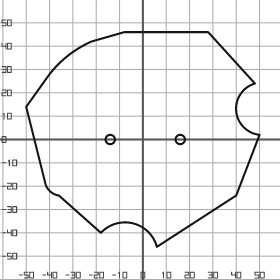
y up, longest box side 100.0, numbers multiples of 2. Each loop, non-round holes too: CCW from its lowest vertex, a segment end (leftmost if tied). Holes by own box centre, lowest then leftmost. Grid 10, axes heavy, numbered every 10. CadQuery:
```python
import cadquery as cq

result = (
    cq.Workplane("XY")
    .moveTo(6.0, -46.0)
    .lineTo(40.0, -24.0)
    .lineTo(50.0, 2.0)
    .threePointArc((40.0, 12.0), (48.0, 24.0))
    .lineTo(28.0, 46.0)
    .lineTo(-8.0, 46.0)
    .lineTo(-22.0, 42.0)
    .threePointArc((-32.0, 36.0), (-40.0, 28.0))
    .lineTo(-50.0, 14.0)
    .lineTo(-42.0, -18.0)
    .threePointArc((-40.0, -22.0), (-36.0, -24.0))
    .lineTo(-18.0, -40.0)
    .threePointArc((-4.0, -36.0), (6.0, -46.0))
    .close()
    .moveTo(-14.0, 0.0)
    .circle(2.0)
    .moveTo(16.0, 0.0)
    .circle(2.0)
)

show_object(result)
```